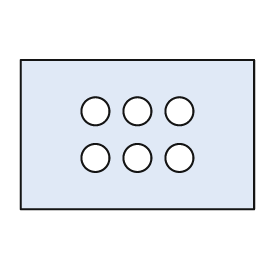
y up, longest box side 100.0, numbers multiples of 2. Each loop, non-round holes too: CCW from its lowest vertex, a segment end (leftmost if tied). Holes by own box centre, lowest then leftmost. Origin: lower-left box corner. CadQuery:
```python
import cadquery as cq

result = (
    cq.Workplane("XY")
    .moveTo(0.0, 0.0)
    .lineTo(100.0, 0.0)
    .lineTo(100.0, 64.0)
    .lineTo(0.0, 64.0)
    .close()
    .moveTo(32.0, 22.0)
    .circle(6.0)
    .moveTo(50.0, 22.0)
    .circle(6.0)
    .moveTo(68.0, 22.0)
    .circle(6.0)
    .moveTo(32.0, 42.0)
    .circle(6.0)
    .moveTo(50.0, 42.0)
    .circle(6.0)
    .moveTo(68.0, 42.0)
    .circle(6.0)
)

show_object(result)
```